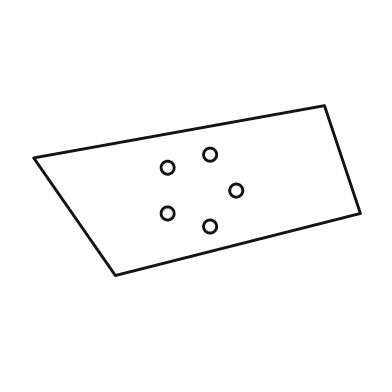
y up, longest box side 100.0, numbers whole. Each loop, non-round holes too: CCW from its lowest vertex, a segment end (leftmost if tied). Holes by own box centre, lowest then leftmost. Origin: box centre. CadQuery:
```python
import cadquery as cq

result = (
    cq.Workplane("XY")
    .moveTo(-25.0, -26.0)
    .lineTo(50.0, -7.0)
    .lineTo(39.0, 26.0)
    .lineTo(-50.0, 10.0)
    .close()
    .moveTo(4.0, -11.0)
    .circle(2.0)
    .moveTo(-9.0, -7.0)
    .circle(2.0)
    .moveTo(12.0, 0.0)
    .circle(2.0)
    .moveTo(-9.0, 7.0)
    .circle(2.0)
    .moveTo(4.0, 11.0)
    .circle(2.0)
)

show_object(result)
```